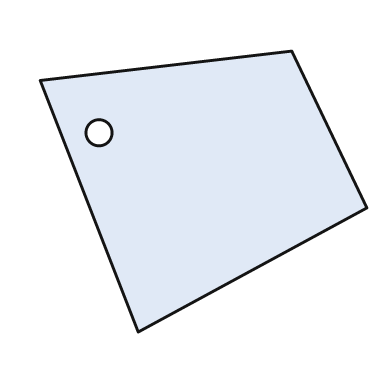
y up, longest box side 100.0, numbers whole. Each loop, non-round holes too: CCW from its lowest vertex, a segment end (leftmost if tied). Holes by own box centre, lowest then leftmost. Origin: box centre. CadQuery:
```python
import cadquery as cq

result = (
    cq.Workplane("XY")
    .moveTo(-20.0, -43.0)
    .lineTo(50.0, -5.0)
    .lineTo(27.0, 43.0)
    .lineTo(-50.0, 34.0)
    .close()
    .moveTo(-32.0, 18.0)
    .circle(4.0)
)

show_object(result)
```